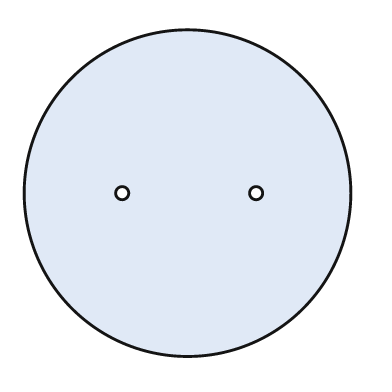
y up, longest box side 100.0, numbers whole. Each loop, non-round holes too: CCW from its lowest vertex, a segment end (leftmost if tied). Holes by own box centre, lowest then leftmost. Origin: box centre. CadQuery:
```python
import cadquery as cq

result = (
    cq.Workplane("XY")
    .moveTo(0.0, 0.0)
    .circle(50.0)
    .moveTo(-20.0, 0.0)
    .circle(2.0)
    .moveTo(21.0, 0.0)
    .circle(2.0)
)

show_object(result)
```